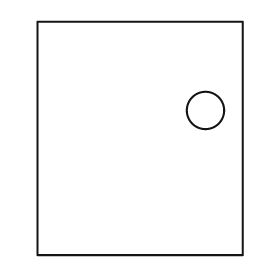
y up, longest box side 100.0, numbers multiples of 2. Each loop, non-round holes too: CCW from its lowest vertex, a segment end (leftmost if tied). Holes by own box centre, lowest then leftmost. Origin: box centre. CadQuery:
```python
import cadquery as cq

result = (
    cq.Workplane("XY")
    .moveTo(-44.0, -50.0)
    .lineTo(44.0, -50.0)
    .lineTo(44.0, 50.0)
    .lineTo(-44.0, 50.0)
    .close()
    .moveTo(28.0, 12.0)
    .circle(8.0)
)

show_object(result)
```